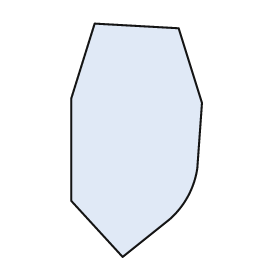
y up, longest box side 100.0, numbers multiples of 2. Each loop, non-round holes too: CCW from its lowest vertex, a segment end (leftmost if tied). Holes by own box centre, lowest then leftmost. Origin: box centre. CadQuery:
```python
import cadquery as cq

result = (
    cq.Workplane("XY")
    .moveTo(-6.0, -50.0)
    .lineTo(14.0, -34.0)
    .threePointArc((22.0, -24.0), (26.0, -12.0))
    .lineTo(28.0, 16.0)
    .lineTo(18.0, 48.0)
    .lineTo(-18.0, 50.0)
    .lineTo(-28.0, 18.0)
    .lineTo(-28.0, -26.0)
    .close()
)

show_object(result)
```